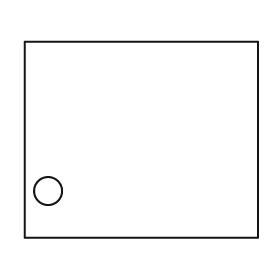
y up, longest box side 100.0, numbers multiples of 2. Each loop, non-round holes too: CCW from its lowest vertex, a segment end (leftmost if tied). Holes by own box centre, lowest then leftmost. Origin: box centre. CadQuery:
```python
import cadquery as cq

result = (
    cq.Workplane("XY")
    .moveTo(-50.0, -42.0)
    .lineTo(50.0, -42.0)
    .lineTo(50.0, 42.0)
    .lineTo(-50.0, 42.0)
    .close()
    .moveTo(-40.0, -22.0)
    .circle(6.0)
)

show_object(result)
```